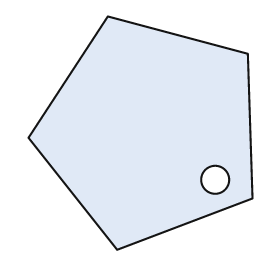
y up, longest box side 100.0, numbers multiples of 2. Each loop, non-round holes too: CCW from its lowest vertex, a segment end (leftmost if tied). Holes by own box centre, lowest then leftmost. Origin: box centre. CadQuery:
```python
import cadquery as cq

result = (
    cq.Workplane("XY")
    .moveTo(-10.0, -50.0)
    .lineTo(48.0, -28.0)
    .lineTo(46.0, 34.0)
    .lineTo(-14.0, 50.0)
    .lineTo(-48.0, -2.0)
    .close()
    .moveTo(32.0, -20.0)
    .circle(6.0)
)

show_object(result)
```